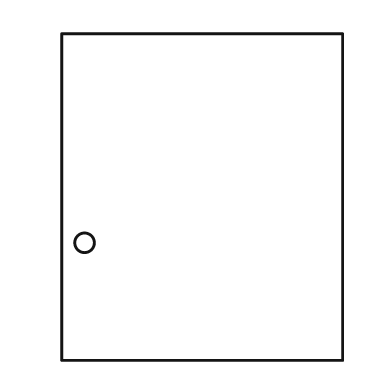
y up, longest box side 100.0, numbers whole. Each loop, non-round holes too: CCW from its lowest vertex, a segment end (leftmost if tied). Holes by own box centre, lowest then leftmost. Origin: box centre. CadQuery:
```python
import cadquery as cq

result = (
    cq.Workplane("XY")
    .moveTo(-43.0, -50.0)
    .lineTo(43.0, -50.0)
    .lineTo(43.0, 50.0)
    .lineTo(-43.0, 50.0)
    .close()
    .moveTo(-36.0, -14.0)
    .circle(3.0)
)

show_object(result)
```